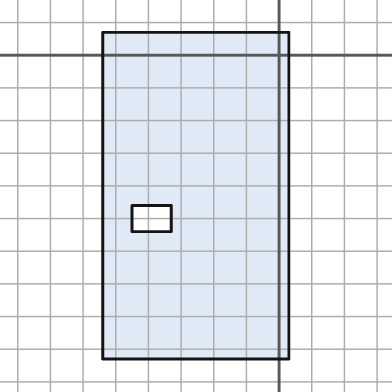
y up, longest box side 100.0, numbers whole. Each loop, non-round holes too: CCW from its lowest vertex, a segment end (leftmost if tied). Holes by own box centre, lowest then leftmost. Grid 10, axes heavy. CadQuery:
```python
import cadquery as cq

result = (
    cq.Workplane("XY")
    .moveTo(-54.0, -93.0)
    .lineTo(3.0, -93.0)
    .lineTo(3.0, 7.0)
    .lineTo(-54.0, 7.0)
    .close()
    .moveTo(-45.0, -54.0)
    .lineTo(-33.0, -54.0)
    .lineTo(-33.0, -46.0)
    .lineTo(-45.0, -46.0)
    .close()
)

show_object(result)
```